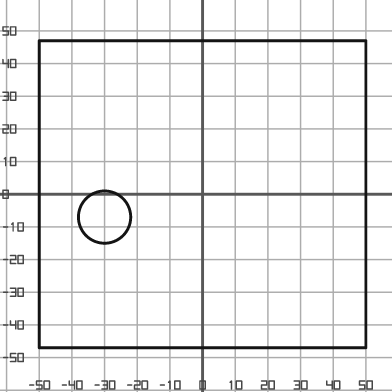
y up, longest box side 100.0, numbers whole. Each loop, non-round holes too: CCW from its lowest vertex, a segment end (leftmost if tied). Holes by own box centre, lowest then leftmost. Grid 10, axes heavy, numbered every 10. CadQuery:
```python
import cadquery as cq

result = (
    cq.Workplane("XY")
    .moveTo(-50.0, -47.0)
    .lineTo(50.0, -47.0)
    .lineTo(50.0, 47.0)
    .lineTo(-50.0, 47.0)
    .close()
    .moveTo(-30.0, -7.0)
    .circle(8.0)
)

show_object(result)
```